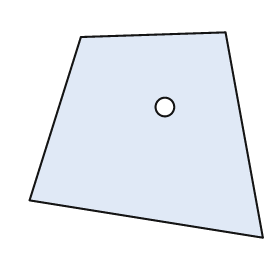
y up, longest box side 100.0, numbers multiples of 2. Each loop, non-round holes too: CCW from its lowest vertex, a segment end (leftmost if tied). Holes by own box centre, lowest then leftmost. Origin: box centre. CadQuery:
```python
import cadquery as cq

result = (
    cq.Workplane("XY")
    .moveTo(50.0, -44.0)
    .lineTo(34.0, 44.0)
    .lineTo(-28.0, 42.0)
    .lineTo(-50.0, -28.0)
    .close()
    .moveTo(8.0, 12.0)
    .circle(4.0)
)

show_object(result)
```